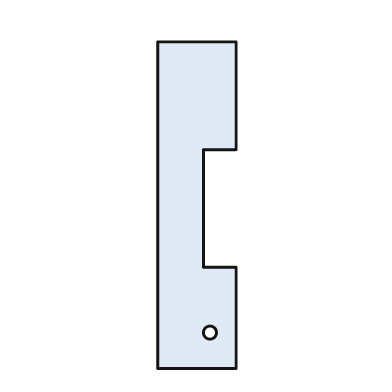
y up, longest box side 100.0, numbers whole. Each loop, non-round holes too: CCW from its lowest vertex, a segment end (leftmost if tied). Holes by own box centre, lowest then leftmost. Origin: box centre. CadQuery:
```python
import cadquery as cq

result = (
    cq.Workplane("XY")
    .moveTo(-12.0, -50.0)
    .lineTo(12.0, -50.0)
    .lineTo(12.0, -19.0)
    .lineTo(2.0, -19.0)
    .lineTo(2.0, 17.0)
    .lineTo(12.0, 17.0)
    .lineTo(12.0, 50.0)
    .lineTo(-12.0, 50.0)
    .close()
    .moveTo(4.0, -39.0)
    .circle(2.0)
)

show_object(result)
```